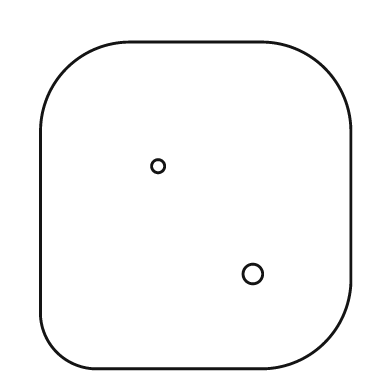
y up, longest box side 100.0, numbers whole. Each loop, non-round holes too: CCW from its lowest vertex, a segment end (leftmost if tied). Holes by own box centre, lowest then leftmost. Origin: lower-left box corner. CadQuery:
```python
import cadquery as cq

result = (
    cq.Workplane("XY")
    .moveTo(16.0, 0.0)
    .lineTo(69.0, 0.0)
    .threePointArc((87.0, 8.0), (95.0, 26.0))
    .lineTo(95.0, 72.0)
    .threePointArc((87.0, 92.0), (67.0, 100.0))
    .lineTo(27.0, 100.0)
    .threePointArc((8.0, 92.0), (0.0, 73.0))
    .lineTo(0.0, 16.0)
    .threePointArc((5.0, 5.0), (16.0, 0.0))
    .close()
    .moveTo(65.0, 29.0)
    .circle(3.0)
    .moveTo(36.0, 62.0)
    .circle(2.0)
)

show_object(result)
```